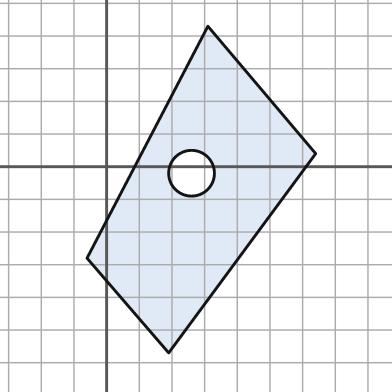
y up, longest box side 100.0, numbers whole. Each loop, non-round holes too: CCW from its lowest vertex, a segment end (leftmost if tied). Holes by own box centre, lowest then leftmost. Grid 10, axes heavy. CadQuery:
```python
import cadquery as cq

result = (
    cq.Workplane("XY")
    .moveTo(19.0, -57.0)
    .lineTo(64.0, 4.0)
    .lineTo(31.0, 43.0)
    .lineTo(-6.0, -28.0)
    .close()
    .moveTo(26.0, -2.0)
    .circle(7.0)
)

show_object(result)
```